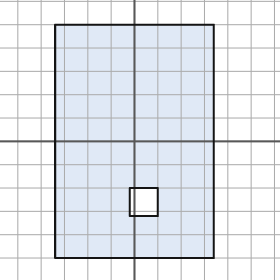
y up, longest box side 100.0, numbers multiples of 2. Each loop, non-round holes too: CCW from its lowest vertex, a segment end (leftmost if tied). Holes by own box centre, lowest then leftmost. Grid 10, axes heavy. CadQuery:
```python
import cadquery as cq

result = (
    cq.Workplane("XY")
    .moveTo(-34.0, -50.0)
    .lineTo(34.0, -50.0)
    .lineTo(34.0, 50.0)
    .lineTo(-34.0, 50.0)
    .close()
    .moveTo(-2.0, -32.0)
    .lineTo(10.0, -32.0)
    .lineTo(10.0, -20.0)
    .lineTo(-2.0, -20.0)
    .close()
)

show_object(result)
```